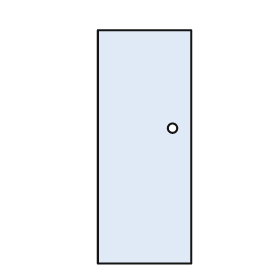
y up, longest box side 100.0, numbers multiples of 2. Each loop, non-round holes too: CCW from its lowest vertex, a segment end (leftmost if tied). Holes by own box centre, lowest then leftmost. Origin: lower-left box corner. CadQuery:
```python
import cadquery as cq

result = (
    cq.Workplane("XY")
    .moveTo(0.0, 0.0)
    .lineTo(40.0, 0.0)
    .lineTo(40.0, 100.0)
    .lineTo(0.0, 100.0)
    .close()
    .moveTo(32.0, 58.0)
    .circle(2.0)
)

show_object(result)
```